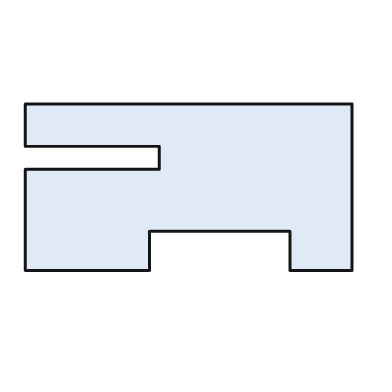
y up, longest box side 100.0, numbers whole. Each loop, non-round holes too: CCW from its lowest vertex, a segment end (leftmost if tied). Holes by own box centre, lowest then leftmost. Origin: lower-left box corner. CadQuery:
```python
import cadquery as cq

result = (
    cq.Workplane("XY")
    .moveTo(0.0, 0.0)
    .lineTo(38.0, 0.0)
    .lineTo(38.0, 12.0)
    .lineTo(81.0, 12.0)
    .lineTo(81.0, 0.0)
    .lineTo(100.0, 0.0)
    .lineTo(100.0, 51.0)
    .lineTo(0.0, 51.0)
    .lineTo(0.0, 38.0)
    .lineTo(41.0, 38.0)
    .lineTo(41.0, 31.0)
    .lineTo(0.0, 31.0)
    .close()
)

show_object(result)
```